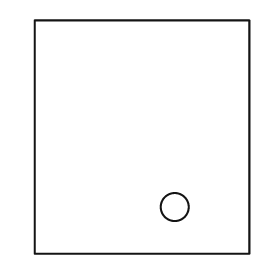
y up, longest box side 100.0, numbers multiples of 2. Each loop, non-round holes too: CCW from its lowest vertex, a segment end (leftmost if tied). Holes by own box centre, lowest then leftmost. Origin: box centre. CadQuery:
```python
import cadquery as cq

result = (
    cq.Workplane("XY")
    .moveTo(-46.0, -50.0)
    .lineTo(46.0, -50.0)
    .lineTo(46.0, 50.0)
    .lineTo(-46.0, 50.0)
    .close()
    .moveTo(14.0, -30.0)
    .circle(6.0)
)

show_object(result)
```